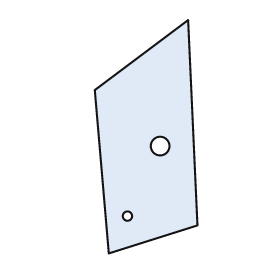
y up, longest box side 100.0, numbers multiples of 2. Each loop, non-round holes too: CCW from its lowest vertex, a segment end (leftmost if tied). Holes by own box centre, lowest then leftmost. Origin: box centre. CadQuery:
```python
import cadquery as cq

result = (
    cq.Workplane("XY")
    .moveTo(-16.0, -50.0)
    .lineTo(22.0, -38.0)
    .lineTo(18.0, 50.0)
    .lineTo(-22.0, 20.0)
    .close()
    .moveTo(-8.0, -34.0)
    .circle(2.0)
    .moveTo(6.0, -4.0)
    .circle(4.0)
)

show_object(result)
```